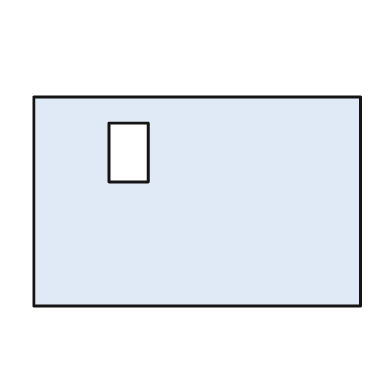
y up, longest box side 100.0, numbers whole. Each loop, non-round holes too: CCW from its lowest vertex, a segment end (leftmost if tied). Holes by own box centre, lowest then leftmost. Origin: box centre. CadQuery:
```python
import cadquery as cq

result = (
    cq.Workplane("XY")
    .moveTo(-50.0, -32.0)
    .lineTo(50.0, -32.0)
    .lineTo(50.0, 32.0)
    .lineTo(-50.0, 32.0)
    .close()
    .moveTo(-27.0, 6.0)
    .lineTo(-15.0, 6.0)
    .lineTo(-15.0, 24.0)
    .lineTo(-27.0, 24.0)
    .close()
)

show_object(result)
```